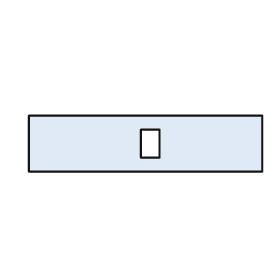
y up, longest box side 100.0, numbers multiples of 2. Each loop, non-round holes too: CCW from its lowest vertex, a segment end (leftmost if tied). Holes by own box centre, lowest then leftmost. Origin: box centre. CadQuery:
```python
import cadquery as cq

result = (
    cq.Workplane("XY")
    .moveTo(-50.0, -12.0)
    .lineTo(50.0, -12.0)
    .lineTo(50.0, 12.0)
    .lineTo(-50.0, 12.0)
    .close()
    .moveTo(-2.0, -6.0)
    .lineTo(6.0, -6.0)
    .lineTo(6.0, 6.0)
    .lineTo(-2.0, 6.0)
    .close()
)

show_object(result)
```